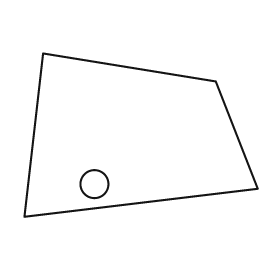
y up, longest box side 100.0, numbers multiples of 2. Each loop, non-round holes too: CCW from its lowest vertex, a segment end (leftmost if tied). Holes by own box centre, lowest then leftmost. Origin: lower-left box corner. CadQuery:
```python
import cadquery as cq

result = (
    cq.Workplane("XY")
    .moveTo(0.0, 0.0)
    .lineTo(100.0, 12.0)
    .lineTo(82.0, 58.0)
    .lineTo(8.0, 70.0)
    .close()
    .moveTo(30.0, 14.0)
    .circle(6.0)
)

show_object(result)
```